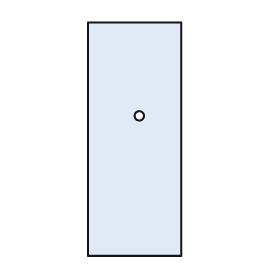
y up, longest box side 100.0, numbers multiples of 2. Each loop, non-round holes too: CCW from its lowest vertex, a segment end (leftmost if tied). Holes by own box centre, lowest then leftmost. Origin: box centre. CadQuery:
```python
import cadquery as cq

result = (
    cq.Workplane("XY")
    .moveTo(-20.0, -50.0)
    .lineTo(20.0, -50.0)
    .lineTo(20.0, 50.0)
    .lineTo(-20.0, 50.0)
    .close()
    .moveTo(2.0, 10.0)
    .circle(2.0)
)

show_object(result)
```